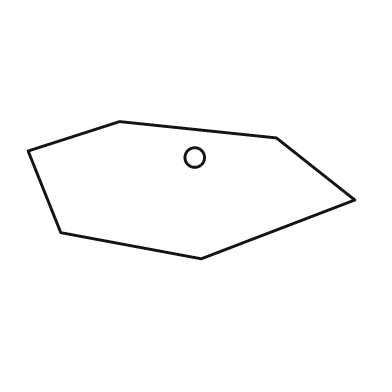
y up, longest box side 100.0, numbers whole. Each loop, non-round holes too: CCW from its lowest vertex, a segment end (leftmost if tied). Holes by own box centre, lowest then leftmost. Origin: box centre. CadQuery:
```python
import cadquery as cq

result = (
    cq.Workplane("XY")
    .moveTo(3.0, -21.0)
    .lineTo(50.0, -3.0)
    .lineTo(26.0, 16.0)
    .lineTo(-22.0, 21.0)
    .lineTo(-50.0, 12.0)
    .lineTo(-40.0, -13.0)
    .close()
    .moveTo(1.0, 10.0)
    .circle(3.0)
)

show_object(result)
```